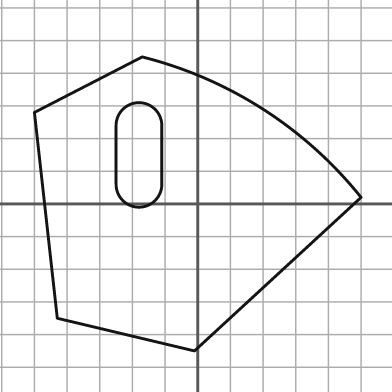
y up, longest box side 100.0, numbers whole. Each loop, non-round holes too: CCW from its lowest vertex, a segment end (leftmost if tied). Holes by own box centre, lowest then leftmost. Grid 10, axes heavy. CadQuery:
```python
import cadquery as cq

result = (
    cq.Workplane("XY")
    .moveTo(-1.0, -45.0)
    .lineTo(50.0, 2.0)
    .threePointArc((20.0, 29.0), (-17.0, 45.0))
    .lineTo(-50.0, 28.0)
    .lineTo(-43.0, -35.0)
    .close()
    .moveTo(-25.0, 6.0)
    .threePointArc((-18.0, -1.0), (-11.0, 6.0))
    .lineTo(-11.0, 24.0)
    .threePointArc((-18.0, 31.0), (-25.0, 24.0))
    .close()
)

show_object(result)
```